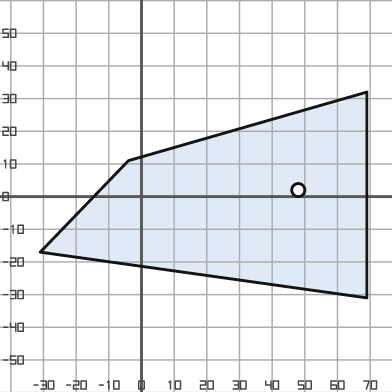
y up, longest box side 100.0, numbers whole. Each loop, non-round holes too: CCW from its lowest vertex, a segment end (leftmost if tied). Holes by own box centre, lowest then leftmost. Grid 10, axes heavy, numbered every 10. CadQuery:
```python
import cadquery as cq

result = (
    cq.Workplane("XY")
    .moveTo(69.0, -31.0)
    .lineTo(69.0, 32.0)
    .lineTo(-4.0, 11.0)
    .lineTo(-31.0, -17.0)
    .close()
    .moveTo(48.0, 2.0)
    .circle(2.0)
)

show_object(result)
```